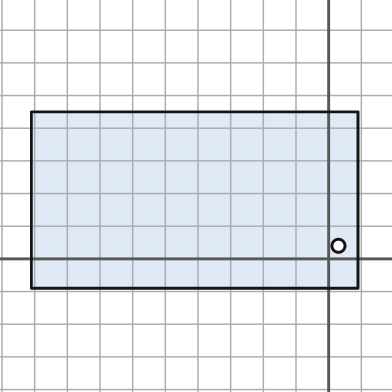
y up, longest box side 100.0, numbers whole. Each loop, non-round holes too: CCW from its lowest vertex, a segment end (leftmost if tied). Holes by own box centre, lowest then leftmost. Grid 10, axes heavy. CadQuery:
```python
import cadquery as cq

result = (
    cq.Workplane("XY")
    .moveTo(-91.0, -9.0)
    .lineTo(9.0, -9.0)
    .lineTo(9.0, 45.0)
    .lineTo(-91.0, 45.0)
    .close()
    .moveTo(3.0, 4.0)
    .circle(2.0)
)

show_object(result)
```